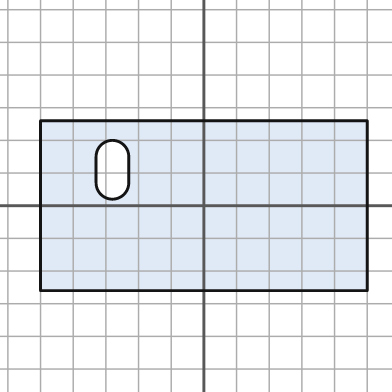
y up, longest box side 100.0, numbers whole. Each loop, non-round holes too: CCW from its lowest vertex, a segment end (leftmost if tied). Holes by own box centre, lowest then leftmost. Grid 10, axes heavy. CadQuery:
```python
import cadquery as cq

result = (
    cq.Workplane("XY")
    .moveTo(-50.0, -26.0)
    .lineTo(50.0, -26.0)
    .lineTo(50.0, 26.0)
    .lineTo(-50.0, 26.0)
    .close()
    .moveTo(-33.0, 7.0)
    .threePointArc((-28.0, 2.0), (-23.0, 7.0))
    .lineTo(-23.0, 15.0)
    .threePointArc((-28.0, 20.0), (-33.0, 15.0))
    .close()
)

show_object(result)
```